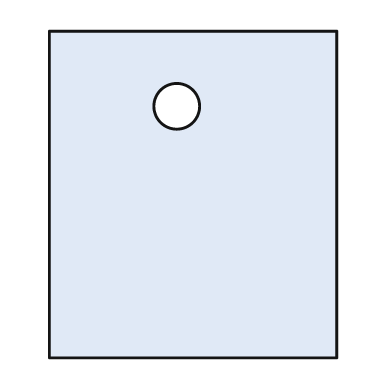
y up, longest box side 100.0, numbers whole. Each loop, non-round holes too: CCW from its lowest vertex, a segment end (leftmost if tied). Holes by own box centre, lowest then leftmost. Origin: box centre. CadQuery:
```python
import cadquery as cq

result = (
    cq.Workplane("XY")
    .moveTo(-44.0, -50.0)
    .lineTo(44.0, -50.0)
    .lineTo(44.0, 50.0)
    .lineTo(-44.0, 50.0)
    .close()
    .moveTo(-5.0, 27.0)
    .circle(7.0)
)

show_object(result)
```